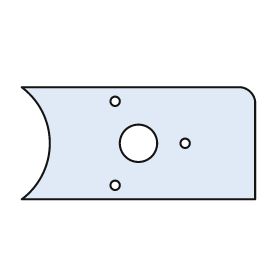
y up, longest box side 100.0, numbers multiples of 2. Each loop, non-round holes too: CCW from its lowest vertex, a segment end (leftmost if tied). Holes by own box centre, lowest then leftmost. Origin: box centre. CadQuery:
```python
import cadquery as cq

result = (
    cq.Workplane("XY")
    .moveTo(-50.0, -24.0)
    .lineTo(50.0, -24.0)
    .lineTo(50.0, 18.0)
    .threePointArc((48.0, 22.0), (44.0, 24.0))
    .lineTo(-50.0, 24.0)
    .threePointArc((-38.0, 0.0), (-50.0, -24.0))
    .close()
    .moveTo(-10.0, -18.0)
    .circle(2.0)
    .moveTo(0.0, 0.0)
    .circle(8.0)
    .moveTo(20.0, 0.0)
    .circle(2.0)
    .moveTo(-10.0, 18.0)
    .circle(2.0)
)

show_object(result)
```